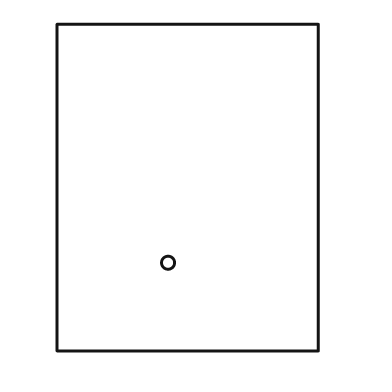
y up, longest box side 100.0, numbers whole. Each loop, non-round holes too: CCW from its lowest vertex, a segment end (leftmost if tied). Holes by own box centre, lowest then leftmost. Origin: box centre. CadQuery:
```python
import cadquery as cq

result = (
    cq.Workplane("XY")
    .moveTo(-40.0, -50.0)
    .lineTo(40.0, -50.0)
    .lineTo(40.0, 50.0)
    .lineTo(-40.0, 50.0)
    .close()
    .moveTo(-6.0, -23.0)
    .circle(2.0)
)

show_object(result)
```